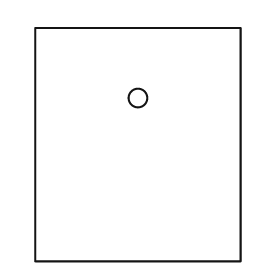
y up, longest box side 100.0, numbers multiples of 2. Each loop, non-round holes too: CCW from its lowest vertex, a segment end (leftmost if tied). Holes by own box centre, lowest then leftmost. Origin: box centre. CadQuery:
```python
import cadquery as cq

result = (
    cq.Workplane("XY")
    .moveTo(-44.0, -50.0)
    .lineTo(44.0, -50.0)
    .lineTo(44.0, 50.0)
    .lineTo(-44.0, 50.0)
    .close()
    .moveTo(0.0, 20.0)
    .circle(4.0)
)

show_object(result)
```